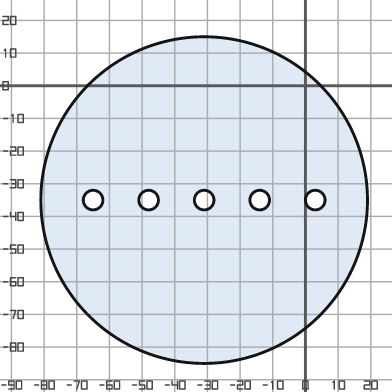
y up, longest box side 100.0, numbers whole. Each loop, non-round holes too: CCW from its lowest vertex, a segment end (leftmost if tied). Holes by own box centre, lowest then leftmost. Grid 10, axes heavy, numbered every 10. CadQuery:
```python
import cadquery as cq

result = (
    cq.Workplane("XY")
    .moveTo(-31.0, -35.0)
    .circle(50.0)
    .moveTo(-65.0, -35.0)
    .circle(3.0)
    .moveTo(-48.0, -35.0)
    .circle(3.0)
    .moveTo(-31.0, -35.0)
    .circle(3.0)
    .moveTo(-14.0, -35.0)
    .circle(3.0)
    .moveTo(3.0, -35.0)
    .circle(3.0)
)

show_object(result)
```